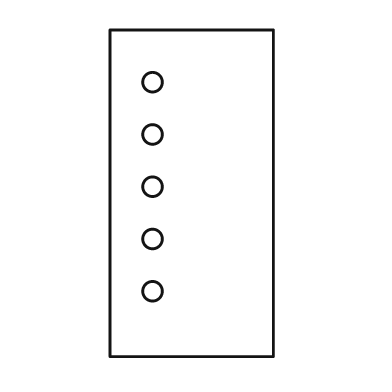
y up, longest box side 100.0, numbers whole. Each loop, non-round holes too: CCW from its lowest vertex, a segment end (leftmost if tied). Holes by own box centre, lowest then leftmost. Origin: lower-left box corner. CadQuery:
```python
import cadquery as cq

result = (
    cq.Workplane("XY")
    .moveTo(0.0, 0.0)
    .lineTo(50.0, 0.0)
    .lineTo(50.0, 100.0)
    .lineTo(0.0, 100.0)
    .close()
    .moveTo(13.0, 20.0)
    .circle(3.0)
    .moveTo(13.0, 36.0)
    .circle(3.0)
    .moveTo(13.0, 52.0)
    .circle(3.0)
    .moveTo(13.0, 68.0)
    .circle(3.0)
    .moveTo(13.0, 84.0)
    .circle(3.0)
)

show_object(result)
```